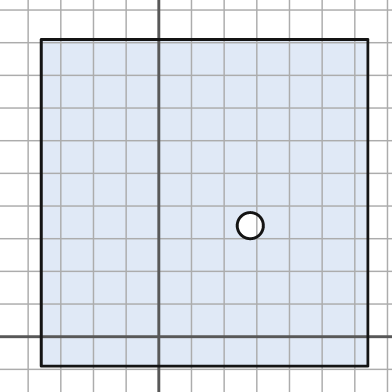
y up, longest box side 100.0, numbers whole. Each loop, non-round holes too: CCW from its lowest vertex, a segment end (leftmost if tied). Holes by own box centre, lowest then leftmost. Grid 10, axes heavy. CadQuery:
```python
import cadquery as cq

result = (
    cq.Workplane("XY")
    .moveTo(-36.0, -9.0)
    .lineTo(64.0, -9.0)
    .lineTo(64.0, 91.0)
    .lineTo(-36.0, 91.0)
    .close()
    .moveTo(28.0, 34.0)
    .circle(4.0)
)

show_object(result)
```